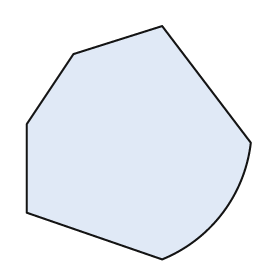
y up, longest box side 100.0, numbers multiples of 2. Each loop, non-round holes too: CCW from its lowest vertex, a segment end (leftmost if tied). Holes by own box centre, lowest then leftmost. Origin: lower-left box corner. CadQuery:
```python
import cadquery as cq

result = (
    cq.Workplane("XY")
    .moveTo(58.0, 0.0)
    .threePointArc((84.0, 20.0), (96.0, 50.0))
    .lineTo(58.0, 100.0)
    .lineTo(20.0, 88.0)
    .lineTo(0.0, 58.0)
    .lineTo(0.0, 20.0)
    .close()
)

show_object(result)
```